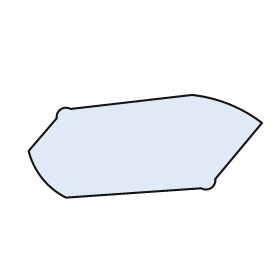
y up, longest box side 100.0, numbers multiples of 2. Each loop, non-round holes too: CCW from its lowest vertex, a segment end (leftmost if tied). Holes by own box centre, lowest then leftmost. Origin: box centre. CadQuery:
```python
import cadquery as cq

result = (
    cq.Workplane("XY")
    .moveTo(-34.0, -22.0)
    .lineTo(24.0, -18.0)
    .threePointArc((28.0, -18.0), (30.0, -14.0))
    .lineTo(50.0, 10.0)
    .threePointArc((36.0, 18.0), (20.0, 22.0))
    .lineTo(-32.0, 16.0)
    .threePointArc((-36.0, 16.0), (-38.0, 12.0))
    .lineTo(-50.0, -2.0)
    .threePointArc((-44.0, -14.0), (-34.0, -22.0))
    .close()
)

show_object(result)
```